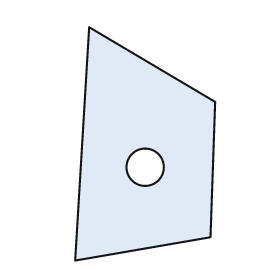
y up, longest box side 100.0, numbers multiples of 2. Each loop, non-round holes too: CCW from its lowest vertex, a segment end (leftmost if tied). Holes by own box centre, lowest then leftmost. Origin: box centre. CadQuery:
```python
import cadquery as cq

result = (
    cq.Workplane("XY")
    .moveTo(-30.0, -50.0)
    .lineTo(28.0, -40.0)
    .lineTo(30.0, 18.0)
    .lineTo(-24.0, 50.0)
    .close()
    .moveTo(0.0, -10.0)
    .circle(8.0)
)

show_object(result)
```